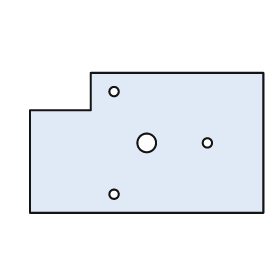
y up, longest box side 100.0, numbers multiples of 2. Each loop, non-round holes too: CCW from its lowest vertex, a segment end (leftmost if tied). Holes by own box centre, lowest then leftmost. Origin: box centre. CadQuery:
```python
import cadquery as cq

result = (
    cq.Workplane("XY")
    .moveTo(-50.0, -30.0)
    .lineTo(50.0, -30.0)
    .lineTo(50.0, 30.0)
    .lineTo(-24.0, 30.0)
    .lineTo(-24.0, 14.0)
    .lineTo(-50.0, 14.0)
    .close()
    .moveTo(-14.0, -22.0)
    .circle(2.0)
    .moveTo(0.0, 0.0)
    .circle(4.0)
    .moveTo(26.0, 0.0)
    .circle(2.0)
    .moveTo(-14.0, 22.0)
    .circle(2.0)
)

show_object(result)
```